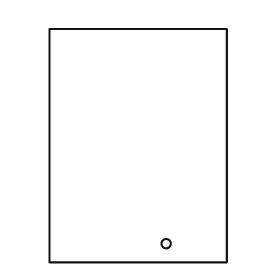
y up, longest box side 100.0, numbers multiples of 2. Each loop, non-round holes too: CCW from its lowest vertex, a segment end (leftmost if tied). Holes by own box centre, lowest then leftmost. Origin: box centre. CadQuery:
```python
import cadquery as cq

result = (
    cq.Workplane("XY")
    .moveTo(-38.0, -50.0)
    .lineTo(38.0, -50.0)
    .lineTo(38.0, 50.0)
    .lineTo(-38.0, 50.0)
    .close()
    .moveTo(12.0, -42.0)
    .circle(2.0)
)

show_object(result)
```